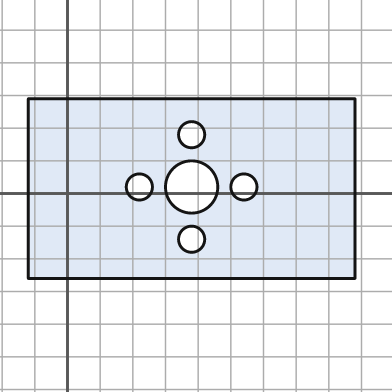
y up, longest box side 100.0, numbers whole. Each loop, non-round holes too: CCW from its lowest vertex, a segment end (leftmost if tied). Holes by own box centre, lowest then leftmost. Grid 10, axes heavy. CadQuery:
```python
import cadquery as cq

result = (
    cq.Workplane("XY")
    .moveTo(-12.0, -26.0)
    .lineTo(88.0, -26.0)
    .lineTo(88.0, 29.0)
    .lineTo(-12.0, 29.0)
    .close()
    .moveTo(38.0, -14.0)
    .circle(4.0)
    .moveTo(22.0, 2.0)
    .circle(4.0)
    .moveTo(38.0, 2.0)
    .circle(8.0)
    .moveTo(54.0, 2.0)
    .circle(4.0)
    .moveTo(38.0, 18.0)
    .circle(4.0)
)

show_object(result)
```